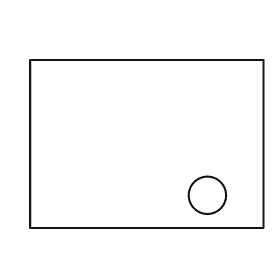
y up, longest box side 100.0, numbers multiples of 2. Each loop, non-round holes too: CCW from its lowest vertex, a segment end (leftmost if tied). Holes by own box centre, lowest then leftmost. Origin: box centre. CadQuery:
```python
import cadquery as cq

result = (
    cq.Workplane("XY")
    .moveTo(-50.0, -36.0)
    .lineTo(50.0, -36.0)
    .lineTo(50.0, 36.0)
    .lineTo(-50.0, 36.0)
    .close()
    .moveTo(26.0, -22.0)
    .circle(8.0)
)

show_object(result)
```